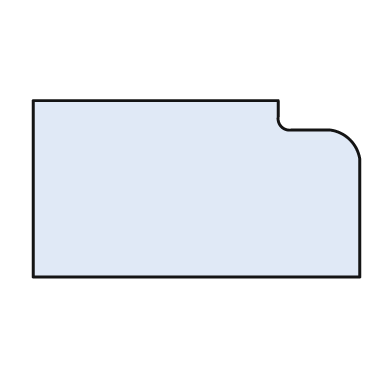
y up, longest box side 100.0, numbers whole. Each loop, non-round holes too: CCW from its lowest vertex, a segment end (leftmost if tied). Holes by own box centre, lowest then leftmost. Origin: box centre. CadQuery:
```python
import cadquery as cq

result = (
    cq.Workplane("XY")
    .moveTo(-50.0, -27.0)
    .lineTo(50.0, -27.0)
    .lineTo(50.0, 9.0)
    .threePointArc((47.0, 15.0), (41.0, 18.0))
    .lineTo(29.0, 18.0)
    .threePointArc((26.0, 19.0), (25.0, 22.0))
    .lineTo(25.0, 27.0)
    .lineTo(-50.0, 27.0)
    .close()
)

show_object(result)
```